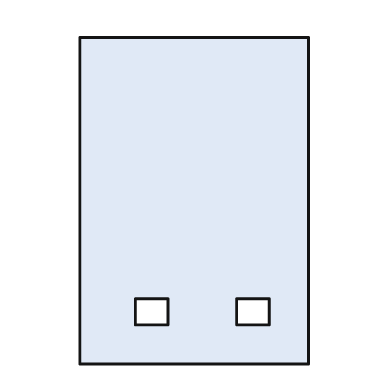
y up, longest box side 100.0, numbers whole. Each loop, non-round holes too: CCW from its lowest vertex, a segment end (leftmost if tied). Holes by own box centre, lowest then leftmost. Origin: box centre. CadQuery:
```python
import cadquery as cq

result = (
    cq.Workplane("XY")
    .moveTo(-35.0, -50.0)
    .lineTo(35.0, -50.0)
    .lineTo(35.0, 50.0)
    .lineTo(-35.0, 50.0)
    .close()
    .moveTo(-18.0, -38.0)
    .lineTo(-8.0, -38.0)
    .lineTo(-8.0, -30.0)
    .lineTo(-18.0, -30.0)
    .close()
    .moveTo(13.0, -38.0)
    .lineTo(23.0, -38.0)
    .lineTo(23.0, -30.0)
    .lineTo(13.0, -30.0)
    .close()
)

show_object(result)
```